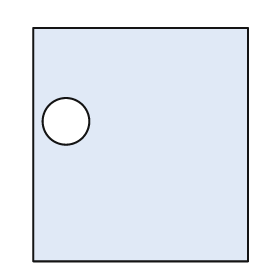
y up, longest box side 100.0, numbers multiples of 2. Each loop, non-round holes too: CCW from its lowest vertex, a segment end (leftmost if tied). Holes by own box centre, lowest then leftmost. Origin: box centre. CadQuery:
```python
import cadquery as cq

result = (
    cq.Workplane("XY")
    .moveTo(-46.0, -50.0)
    .lineTo(46.0, -50.0)
    .lineTo(46.0, 50.0)
    .lineTo(-46.0, 50.0)
    .close()
    .moveTo(-32.0, 10.0)
    .circle(10.0)
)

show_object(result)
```